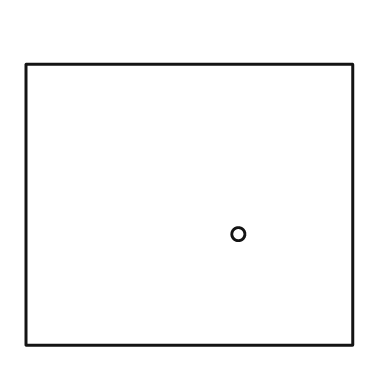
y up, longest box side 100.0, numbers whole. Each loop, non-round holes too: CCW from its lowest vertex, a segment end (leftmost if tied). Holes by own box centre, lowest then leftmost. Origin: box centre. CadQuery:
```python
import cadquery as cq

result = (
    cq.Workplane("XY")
    .moveTo(-50.0, -43.0)
    .lineTo(50.0, -43.0)
    .lineTo(50.0, 43.0)
    .lineTo(-50.0, 43.0)
    .close()
    .moveTo(15.0, -9.0)
    .circle(2.0)
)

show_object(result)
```